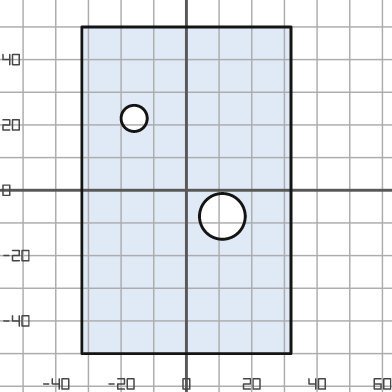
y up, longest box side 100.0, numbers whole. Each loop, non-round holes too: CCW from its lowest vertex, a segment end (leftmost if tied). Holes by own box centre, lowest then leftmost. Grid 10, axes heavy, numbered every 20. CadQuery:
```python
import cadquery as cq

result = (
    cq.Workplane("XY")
    .moveTo(-32.0, -50.0)
    .lineTo(32.0, -50.0)
    .lineTo(32.0, 50.0)
    .lineTo(-32.0, 50.0)
    .close()
    .moveTo(11.0, -8.0)
    .circle(7.0)
    .moveTo(-16.0, 22.0)
    .circle(4.0)
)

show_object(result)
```